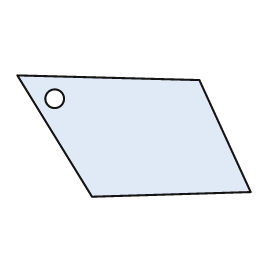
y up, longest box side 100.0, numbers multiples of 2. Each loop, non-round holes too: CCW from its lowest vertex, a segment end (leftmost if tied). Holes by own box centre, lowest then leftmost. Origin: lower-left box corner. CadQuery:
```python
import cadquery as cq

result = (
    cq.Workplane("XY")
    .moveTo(32.0, 0.0)
    .lineTo(100.0, 2.0)
    .lineTo(78.0, 50.0)
    .lineTo(0.0, 52.0)
    .close()
    .moveTo(16.0, 42.0)
    .circle(4.0)
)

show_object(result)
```